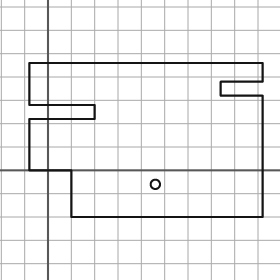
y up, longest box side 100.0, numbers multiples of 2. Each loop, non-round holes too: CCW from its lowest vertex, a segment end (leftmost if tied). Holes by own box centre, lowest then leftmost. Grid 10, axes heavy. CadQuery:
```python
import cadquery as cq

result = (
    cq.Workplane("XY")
    .moveTo(10.0, -20.0)
    .lineTo(92.0, -20.0)
    .lineTo(92.0, 32.0)
    .lineTo(74.0, 32.0)
    .lineTo(74.0, 38.0)
    .lineTo(92.0, 38.0)
    .lineTo(92.0, 46.0)
    .lineTo(-8.0, 46.0)
    .lineTo(-8.0, 28.0)
    .lineTo(20.0, 28.0)
    .lineTo(20.0, 22.0)
    .lineTo(-8.0, 22.0)
    .lineTo(-8.0, 0.0)
    .lineTo(10.0, 0.0)
    .close()
    .moveTo(46.0, -6.0)
    .circle(2.0)
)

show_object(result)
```